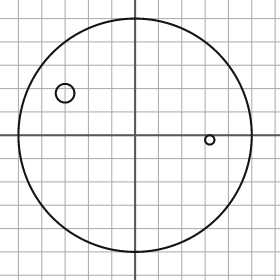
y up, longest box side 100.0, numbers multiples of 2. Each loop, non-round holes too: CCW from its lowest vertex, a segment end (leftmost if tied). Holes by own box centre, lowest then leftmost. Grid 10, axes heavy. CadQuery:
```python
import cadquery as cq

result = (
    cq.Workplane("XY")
    .moveTo(0.0, 0.0)
    .circle(50.0)
    .moveTo(32.0, -2.0)
    .circle(2.0)
    .moveTo(-30.0, 18.0)
    .circle(4.0)
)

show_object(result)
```